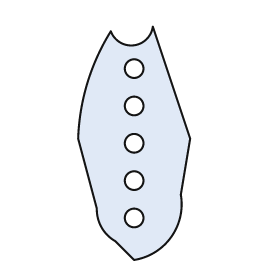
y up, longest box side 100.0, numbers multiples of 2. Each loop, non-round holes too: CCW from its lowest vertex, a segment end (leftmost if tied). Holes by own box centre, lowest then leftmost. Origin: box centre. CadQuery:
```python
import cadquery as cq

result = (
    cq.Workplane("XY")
    .moveTo(0.0, -50.0)
    .threePointArc((16.0, -40.0), (20.0, -22.0))
    .lineTo(24.0, 2.0)
    .lineTo(8.0, 50.0)
    .threePointArc((0.0, 42.0), (-10.0, 48.0))
    .threePointArc((-20.0, 26.0), (-24.0, 2.0))
    .lineTo(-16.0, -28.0)
    .threePointArc((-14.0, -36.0), (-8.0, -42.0))
    .close()
    .moveTo(0.0, -32.0)
    .circle(4.0)
    .moveTo(0.0, -16.0)
    .circle(4.0)
    .moveTo(0.0, 0.0)
    .circle(4.0)
    .moveTo(0.0, 16.0)
    .circle(4.0)
    .moveTo(0.0, 32.0)
    .circle(4.0)
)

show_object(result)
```